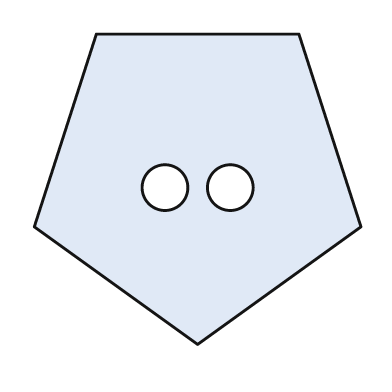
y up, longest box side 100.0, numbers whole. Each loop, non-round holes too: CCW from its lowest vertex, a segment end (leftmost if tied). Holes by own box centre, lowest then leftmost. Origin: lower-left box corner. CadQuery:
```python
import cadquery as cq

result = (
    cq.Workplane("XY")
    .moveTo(50.0, 0.0)
    .lineTo(100.0, 36.0)
    .lineTo(81.0, 95.0)
    .lineTo(19.0, 95.0)
    .lineTo(0.0, 36.0)
    .close()
    .moveTo(40.0, 48.0)
    .circle(7.0)
    .moveTo(60.0, 48.0)
    .circle(7.0)
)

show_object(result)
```